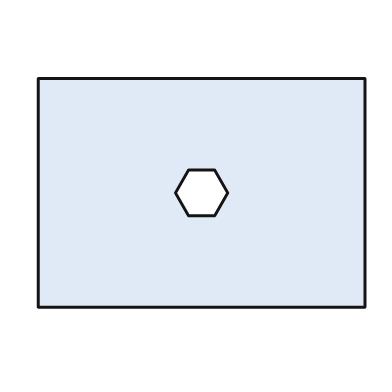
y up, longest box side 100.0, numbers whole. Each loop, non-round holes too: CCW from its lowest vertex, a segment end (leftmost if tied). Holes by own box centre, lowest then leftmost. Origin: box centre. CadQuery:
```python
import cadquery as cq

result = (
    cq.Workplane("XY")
    .moveTo(-50.0, -35.0)
    .lineTo(50.0, -35.0)
    .lineTo(50.0, 35.0)
    .lineTo(-50.0, 35.0)
    .close()
    .moveTo(-4.0, -7.0)
    .lineTo(4.0, -7.0)
    .lineTo(8.0, 0.0)
    .lineTo(4.0, 7.0)
    .lineTo(-4.0, 7.0)
    .lineTo(-8.0, 0.0)
    .close()
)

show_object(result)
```